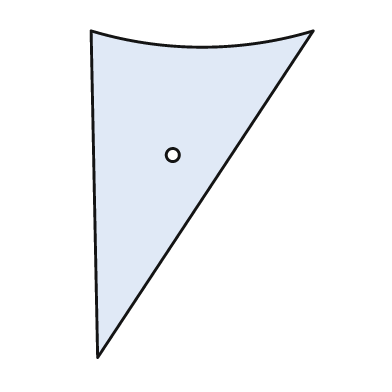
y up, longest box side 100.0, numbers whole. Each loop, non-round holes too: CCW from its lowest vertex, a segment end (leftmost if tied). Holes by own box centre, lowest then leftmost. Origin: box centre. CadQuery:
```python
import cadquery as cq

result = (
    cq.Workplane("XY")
    .moveTo(-32.0, -50.0)
    .lineTo(34.0, 50.0)
    .threePointArc((0.0, 45.0), (-34.0, 50.0))
    .close()
    .moveTo(-9.0, 12.0)
    .circle(2.0)
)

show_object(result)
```